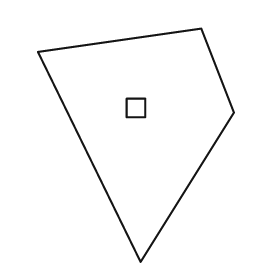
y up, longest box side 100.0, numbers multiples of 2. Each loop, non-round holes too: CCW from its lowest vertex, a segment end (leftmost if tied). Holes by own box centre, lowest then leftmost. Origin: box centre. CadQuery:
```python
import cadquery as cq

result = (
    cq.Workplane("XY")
    .moveTo(2.0, -50.0)
    .lineTo(42.0, 14.0)
    .lineTo(28.0, 50.0)
    .lineTo(-42.0, 40.0)
    .close()
    .moveTo(-4.0, 12.0)
    .lineTo(4.0, 12.0)
    .lineTo(4.0, 20.0)
    .lineTo(-4.0, 20.0)
    .close()
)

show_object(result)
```